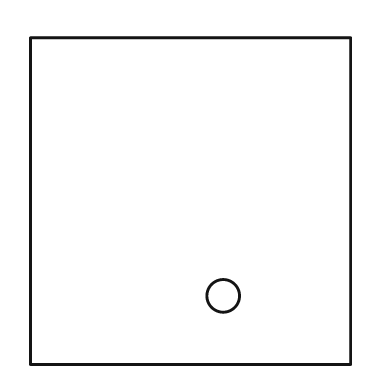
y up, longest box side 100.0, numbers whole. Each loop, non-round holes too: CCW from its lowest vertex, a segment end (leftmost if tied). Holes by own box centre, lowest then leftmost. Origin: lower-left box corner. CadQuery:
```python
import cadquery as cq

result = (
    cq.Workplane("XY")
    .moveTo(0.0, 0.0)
    .lineTo(98.0, 0.0)
    .lineTo(98.0, 100.0)
    .lineTo(0.0, 100.0)
    .close()
    .moveTo(59.0, 21.0)
    .circle(5.0)
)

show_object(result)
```